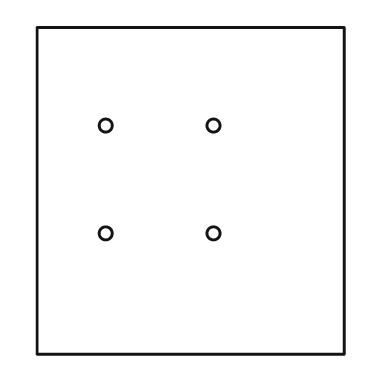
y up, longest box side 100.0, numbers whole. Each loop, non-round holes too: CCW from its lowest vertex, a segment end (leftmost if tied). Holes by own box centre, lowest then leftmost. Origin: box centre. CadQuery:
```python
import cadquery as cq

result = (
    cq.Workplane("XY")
    .moveTo(-47.0, -50.0)
    .lineTo(47.0, -50.0)
    .lineTo(47.0, 50.0)
    .lineTo(-47.0, 50.0)
    .close()
    .moveTo(-26.0, -13.0)
    .circle(2.0)
    .moveTo(7.0, -13.0)
    .circle(2.0)
    .moveTo(-26.0, 20.0)
    .circle(2.0)
    .moveTo(7.0, 20.0)
    .circle(2.0)
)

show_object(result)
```